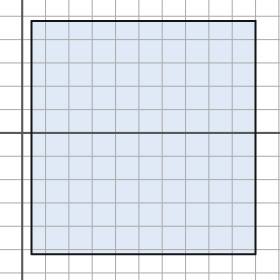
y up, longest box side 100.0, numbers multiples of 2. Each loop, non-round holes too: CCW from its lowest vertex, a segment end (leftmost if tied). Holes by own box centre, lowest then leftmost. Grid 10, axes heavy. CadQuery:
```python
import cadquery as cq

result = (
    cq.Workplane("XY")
    .moveTo(4.0, -52.0)
    .lineTo(100.0, -52.0)
    .lineTo(100.0, 48.0)
    .lineTo(4.0, 48.0)
    .close()
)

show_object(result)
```